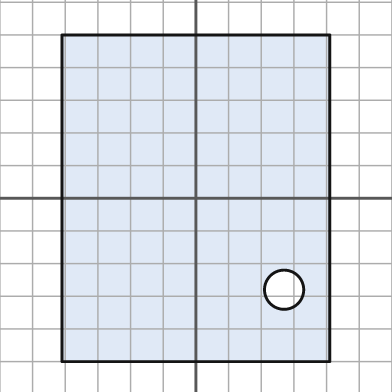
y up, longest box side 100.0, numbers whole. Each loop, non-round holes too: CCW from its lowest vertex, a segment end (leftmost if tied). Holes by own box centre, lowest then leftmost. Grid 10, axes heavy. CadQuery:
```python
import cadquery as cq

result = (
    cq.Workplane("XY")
    .moveTo(-41.0, -50.0)
    .lineTo(41.0, -50.0)
    .lineTo(41.0, 50.0)
    .lineTo(-41.0, 50.0)
    .close()
    .moveTo(27.0, -28.0)
    .circle(6.0)
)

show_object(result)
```